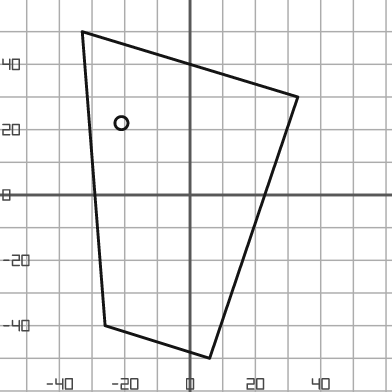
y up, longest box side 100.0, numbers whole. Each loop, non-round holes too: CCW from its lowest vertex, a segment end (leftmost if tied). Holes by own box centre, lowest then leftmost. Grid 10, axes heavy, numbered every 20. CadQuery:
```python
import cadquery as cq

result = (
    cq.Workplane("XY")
    .moveTo(6.0, -50.0)
    .lineTo(33.0, 30.0)
    .lineTo(-33.0, 50.0)
    .lineTo(-26.0, -40.0)
    .close()
    .moveTo(-21.0, 22.0)
    .circle(2.0)
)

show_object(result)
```